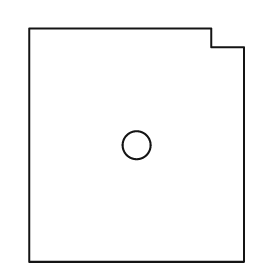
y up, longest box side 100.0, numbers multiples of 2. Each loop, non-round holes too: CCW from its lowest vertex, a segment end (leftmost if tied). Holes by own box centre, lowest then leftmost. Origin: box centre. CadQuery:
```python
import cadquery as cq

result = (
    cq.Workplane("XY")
    .moveTo(-46.0, -50.0)
    .lineTo(46.0, -50.0)
    .lineTo(46.0, 42.0)
    .lineTo(32.0, 42.0)
    .lineTo(32.0, 50.0)
    .lineTo(-46.0, 50.0)
    .close()
    .moveTo(0.0, 0.0)
    .circle(6.0)
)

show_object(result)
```